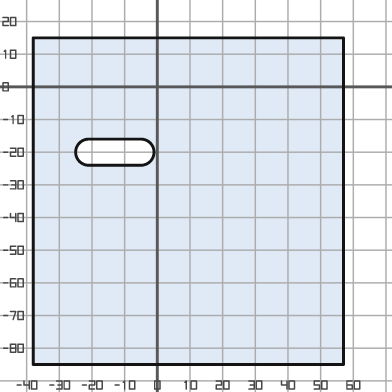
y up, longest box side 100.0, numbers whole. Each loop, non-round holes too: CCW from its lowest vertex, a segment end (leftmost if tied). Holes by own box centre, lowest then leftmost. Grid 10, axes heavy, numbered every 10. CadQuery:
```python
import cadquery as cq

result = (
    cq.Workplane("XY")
    .moveTo(-38.0, -85.0)
    .lineTo(57.0, -85.0)
    .lineTo(57.0, 15.0)
    .lineTo(-38.0, 15.0)
    .close()
    .moveTo(-21.0, -24.0)
    .lineTo(-5.0, -24.0)
    .threePointArc((-1.0, -20.0), (-5.0, -16.0))
    .lineTo(-21.0, -16.0)
    .threePointArc((-25.0, -20.0), (-21.0, -24.0))
    .close()
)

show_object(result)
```